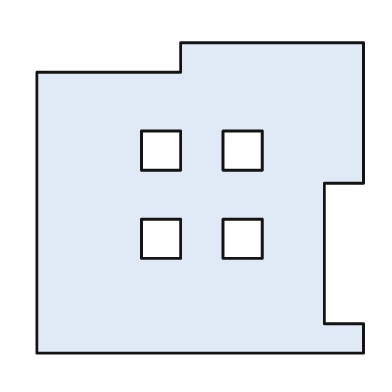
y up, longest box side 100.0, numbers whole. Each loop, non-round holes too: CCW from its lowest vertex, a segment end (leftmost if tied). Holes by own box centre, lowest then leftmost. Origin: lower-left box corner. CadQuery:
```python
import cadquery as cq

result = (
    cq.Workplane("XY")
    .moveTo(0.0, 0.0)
    .lineTo(100.0, 0.0)
    .lineTo(100.0, 9.0)
    .lineTo(88.0, 9.0)
    .lineTo(88.0, 52.0)
    .lineTo(100.0, 52.0)
    .lineTo(100.0, 95.0)
    .lineTo(44.0, 95.0)
    .lineTo(44.0, 86.0)
    .lineTo(0.0, 86.0)
    .close()
    .moveTo(32.0, 29.0)
    .lineTo(44.0, 29.0)
    .lineTo(44.0, 41.0)
    .lineTo(32.0, 41.0)
    .close()
    .moveTo(57.0, 29.0)
    .lineTo(69.0, 29.0)
    .lineTo(69.0, 41.0)
    .lineTo(57.0, 41.0)
    .close()
    .moveTo(32.0, 56.0)
    .lineTo(44.0, 56.0)
    .lineTo(44.0, 68.0)
    .lineTo(32.0, 68.0)
    .close()
    .moveTo(57.0, 56.0)
    .lineTo(69.0, 56.0)
    .lineTo(69.0, 68.0)
    .lineTo(57.0, 68.0)
    .close()
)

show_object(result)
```